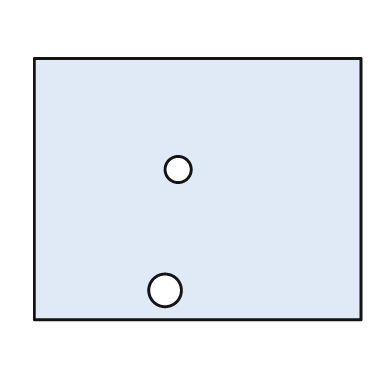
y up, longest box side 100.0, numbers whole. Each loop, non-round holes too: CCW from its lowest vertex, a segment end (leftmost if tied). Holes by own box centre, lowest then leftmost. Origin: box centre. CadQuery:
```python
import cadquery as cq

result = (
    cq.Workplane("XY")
    .moveTo(-50.0, -40.0)
    .lineTo(50.0, -40.0)
    .lineTo(50.0, 40.0)
    .lineTo(-50.0, 40.0)
    .close()
    .moveTo(-10.0, -31.0)
    .circle(5.0)
    .moveTo(-6.0, 6.0)
    .circle(4.0)
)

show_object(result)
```